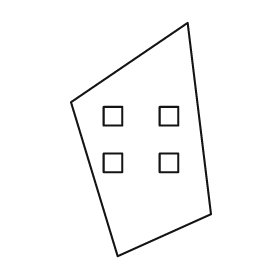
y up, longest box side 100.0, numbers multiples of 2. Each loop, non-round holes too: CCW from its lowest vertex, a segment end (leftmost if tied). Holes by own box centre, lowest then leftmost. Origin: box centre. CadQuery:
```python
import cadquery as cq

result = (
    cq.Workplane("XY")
    .moveTo(-10.0, -50.0)
    .lineTo(30.0, -32.0)
    .lineTo(20.0, 50.0)
    .lineTo(-30.0, 16.0)
    .close()
    .moveTo(-16.0, -14.0)
    .lineTo(-8.0, -14.0)
    .lineTo(-8.0, -6.0)
    .lineTo(-16.0, -6.0)
    .close()
    .moveTo(8.0, -14.0)
    .lineTo(16.0, -14.0)
    .lineTo(16.0, -6.0)
    .lineTo(8.0, -6.0)
    .close()
    .moveTo(-16.0, 6.0)
    .lineTo(-8.0, 6.0)
    .lineTo(-8.0, 14.0)
    .lineTo(-16.0, 14.0)
    .close()
    .moveTo(8.0, 6.0)
    .lineTo(16.0, 6.0)
    .lineTo(16.0, 14.0)
    .lineTo(8.0, 14.0)
    .close()
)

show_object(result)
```